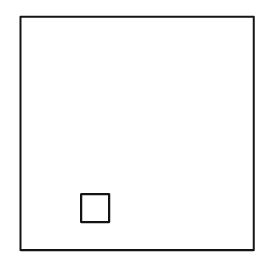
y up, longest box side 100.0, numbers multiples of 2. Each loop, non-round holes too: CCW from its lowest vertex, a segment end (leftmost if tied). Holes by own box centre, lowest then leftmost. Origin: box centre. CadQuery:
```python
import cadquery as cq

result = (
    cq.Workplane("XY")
    .moveTo(-50.0, -50.0)
    .lineTo(50.0, -50.0)
    .lineTo(50.0, 50.0)
    .lineTo(-50.0, 50.0)
    .close()
    .moveTo(-24.0, -38.0)
    .lineTo(-12.0, -38.0)
    .lineTo(-12.0, -26.0)
    .lineTo(-24.0, -26.0)
    .close()
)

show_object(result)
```